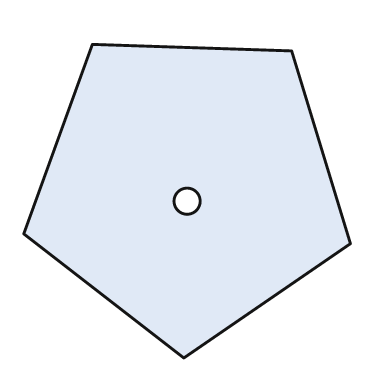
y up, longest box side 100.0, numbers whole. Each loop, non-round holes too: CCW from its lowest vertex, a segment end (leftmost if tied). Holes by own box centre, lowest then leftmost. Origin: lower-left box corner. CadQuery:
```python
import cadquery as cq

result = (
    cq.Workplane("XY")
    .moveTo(49.0, 0.0)
    .lineTo(100.0, 35.0)
    .lineTo(82.0, 94.0)
    .lineTo(21.0, 96.0)
    .lineTo(0.0, 38.0)
    .close()
    .moveTo(50.0, 48.0)
    .circle(4.0)
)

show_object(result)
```